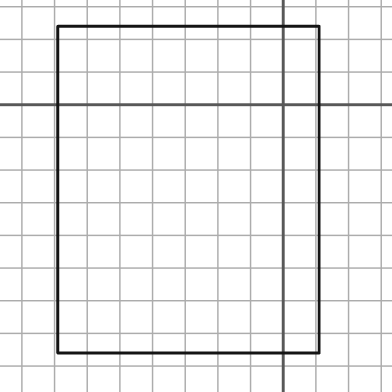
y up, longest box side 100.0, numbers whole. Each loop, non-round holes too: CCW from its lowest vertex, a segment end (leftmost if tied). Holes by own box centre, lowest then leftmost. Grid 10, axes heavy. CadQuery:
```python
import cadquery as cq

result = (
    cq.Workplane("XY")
    .moveTo(-69.0, -76.0)
    .lineTo(11.0, -76.0)
    .lineTo(11.0, 24.0)
    .lineTo(-69.0, 24.0)
    .close()
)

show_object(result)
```